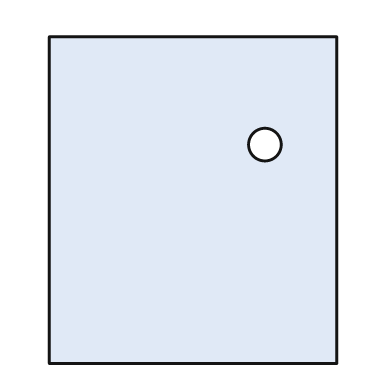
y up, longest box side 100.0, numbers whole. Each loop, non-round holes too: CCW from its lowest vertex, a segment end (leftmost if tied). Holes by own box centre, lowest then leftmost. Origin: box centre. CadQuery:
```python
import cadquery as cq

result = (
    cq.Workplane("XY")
    .moveTo(-44.0, -50.0)
    .lineTo(44.0, -50.0)
    .lineTo(44.0, 50.0)
    .lineTo(-44.0, 50.0)
    .close()
    .moveTo(22.0, 17.0)
    .circle(5.0)
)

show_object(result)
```